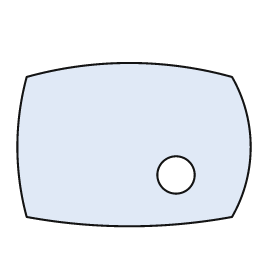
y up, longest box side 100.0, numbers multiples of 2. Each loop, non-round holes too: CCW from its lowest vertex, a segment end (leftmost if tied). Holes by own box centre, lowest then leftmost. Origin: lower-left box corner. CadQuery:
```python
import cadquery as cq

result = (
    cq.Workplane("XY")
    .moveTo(4.0, 4.0)
    .threePointArc((48.0, 0.0), (92.0, 4.0))
    .threePointArc((100.0, 34.0), (92.0, 64.0))
    .threePointArc((48.0, 70.0), (4.0, 64.0))
    .threePointArc((0.0, 34.0), (4.0, 4.0))
    .close()
    .moveTo(68.0, 22.0)
    .circle(8.0)
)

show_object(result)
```